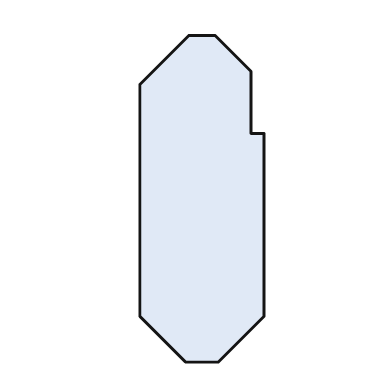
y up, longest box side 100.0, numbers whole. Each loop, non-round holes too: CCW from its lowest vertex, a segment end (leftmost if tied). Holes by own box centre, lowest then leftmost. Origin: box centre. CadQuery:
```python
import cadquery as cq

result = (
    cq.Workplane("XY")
    .moveTo(-5.0, -50.0)
    .lineTo(5.0, -50.0)
    .lineTo(19.0, -36.0)
    .lineTo(19.0, 20.0)
    .lineTo(15.0, 20.0)
    .lineTo(15.0, 39.0)
    .lineTo(4.0, 50.0)
    .lineTo(-4.0, 50.0)
    .lineTo(-19.0, 35.0)
    .lineTo(-19.0, -36.0)
    .close()
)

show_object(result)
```